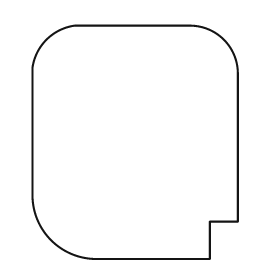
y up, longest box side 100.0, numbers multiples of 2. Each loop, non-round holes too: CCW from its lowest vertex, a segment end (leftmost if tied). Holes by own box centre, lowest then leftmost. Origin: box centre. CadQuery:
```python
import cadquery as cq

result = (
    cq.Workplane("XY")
    .moveTo(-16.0, -50.0)
    .lineTo(32.0, -50.0)
    .lineTo(32.0, -34.0)
    .lineTo(44.0, -34.0)
    .lineTo(44.0, 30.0)
    .threePointArc((38.0, 44.0), (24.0, 50.0))
    .lineTo(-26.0, 50.0)
    .threePointArc((-38.0, 44.0), (-44.0, 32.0))
    .lineTo(-44.0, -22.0)
    .threePointArc((-36.0, -42.0), (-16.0, -50.0))
    .close()
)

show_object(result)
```